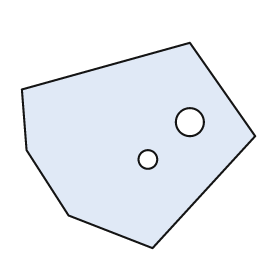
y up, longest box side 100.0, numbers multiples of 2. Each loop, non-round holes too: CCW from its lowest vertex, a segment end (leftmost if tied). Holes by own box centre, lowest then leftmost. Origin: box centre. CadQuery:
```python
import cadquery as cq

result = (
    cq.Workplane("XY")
    .moveTo(6.0, -44.0)
    .lineTo(50.0, 4.0)
    .lineTo(22.0, 44.0)
    .lineTo(-50.0, 24.0)
    .lineTo(-48.0, -2.0)
    .lineTo(-30.0, -30.0)
    .close()
    .moveTo(4.0, -6.0)
    .circle(4.0)
    .moveTo(22.0, 10.0)
    .circle(6.0)
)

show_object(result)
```